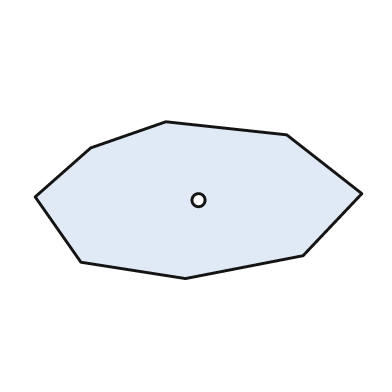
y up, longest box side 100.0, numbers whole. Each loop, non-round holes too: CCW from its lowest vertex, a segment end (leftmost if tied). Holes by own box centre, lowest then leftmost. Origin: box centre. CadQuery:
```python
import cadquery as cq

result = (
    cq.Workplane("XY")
    .moveTo(-4.0, -24.0)
    .lineTo(32.0, -17.0)
    .lineTo(50.0, 2.0)
    .lineTo(27.0, 20.0)
    .lineTo(-10.0, 24.0)
    .lineTo(-33.0, 16.0)
    .lineTo(-50.0, 1.0)
    .lineTo(-36.0, -19.0)
    .close()
    .moveTo(0.0, 0.0)
    .circle(2.0)
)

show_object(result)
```